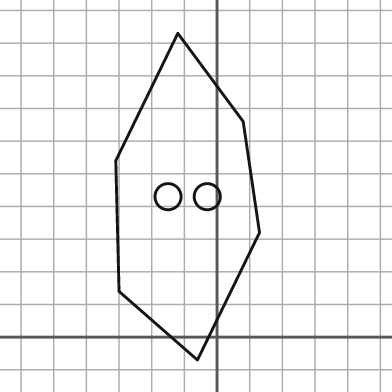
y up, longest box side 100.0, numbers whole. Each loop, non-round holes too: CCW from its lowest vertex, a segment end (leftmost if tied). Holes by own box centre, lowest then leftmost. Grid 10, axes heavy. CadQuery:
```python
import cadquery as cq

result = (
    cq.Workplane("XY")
    .moveTo(-6.0, -7.0)
    .lineTo(13.0, 32.0)
    .lineTo(8.0, 66.0)
    .lineTo(-12.0, 93.0)
    .lineTo(-31.0, 54.0)
    .lineTo(-30.0, 14.0)
    .close()
    .moveTo(-15.0, 43.0)
    .circle(4.0)
    .moveTo(-3.0, 43.0)
    .circle(4.0)
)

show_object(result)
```